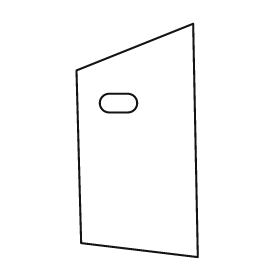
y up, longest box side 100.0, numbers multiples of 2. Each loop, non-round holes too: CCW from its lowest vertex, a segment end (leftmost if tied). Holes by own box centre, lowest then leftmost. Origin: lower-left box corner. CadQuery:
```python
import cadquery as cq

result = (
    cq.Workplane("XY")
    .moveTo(52.0, 0.0)
    .lineTo(50.0, 100.0)
    .lineTo(0.0, 80.0)
    .lineTo(2.0, 6.0)
    .close()
    .moveTo(14.0, 62.0)
    .lineTo(22.0, 62.0)
    .threePointArc((26.0, 66.0), (22.0, 70.0))
    .lineTo(14.0, 70.0)
    .threePointArc((10.0, 66.0), (14.0, 62.0))
    .close()
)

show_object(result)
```